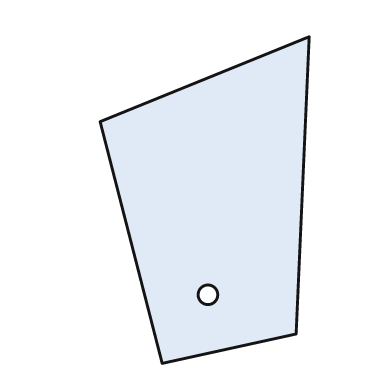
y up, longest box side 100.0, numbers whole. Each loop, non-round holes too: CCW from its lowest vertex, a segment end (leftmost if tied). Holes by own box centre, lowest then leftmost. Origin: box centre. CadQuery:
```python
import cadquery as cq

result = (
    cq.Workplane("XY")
    .moveTo(-13.0, -50.0)
    .lineTo(28.0, -41.0)
    .lineTo(32.0, 50.0)
    .lineTo(-32.0, 24.0)
    .close()
    .moveTo(1.0, -29.0)
    .circle(3.0)
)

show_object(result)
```